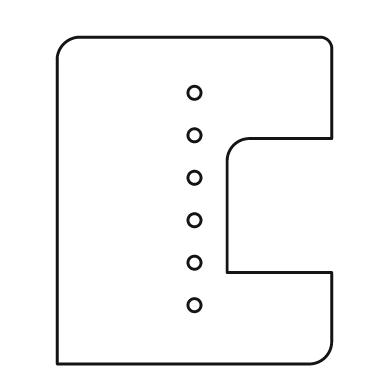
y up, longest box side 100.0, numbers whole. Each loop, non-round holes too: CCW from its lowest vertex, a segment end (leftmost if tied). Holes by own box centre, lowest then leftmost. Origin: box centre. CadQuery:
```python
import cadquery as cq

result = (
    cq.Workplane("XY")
    .moveTo(-42.0, -50.0)
    .lineTo(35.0, -50.0)
    .threePointArc((40.0, -48.0), (42.0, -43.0))
    .lineTo(42.0, -22.0)
    .lineTo(10.0, -22.0)
    .lineTo(10.0, 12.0)
    .threePointArc((12.0, 17.0), (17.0, 19.0))
    .lineTo(42.0, 19.0)
    .lineTo(42.0, 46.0)
    .threePointArc((41.0, 49.0), (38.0, 50.0))
    .lineTo(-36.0, 50.0)
    .threePointArc((-40.0, 48.0), (-42.0, 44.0))
    .close()
    .moveTo(0.0, -32.0)
    .circle(2.0)
    .moveTo(0.0, -19.0)
    .circle(2.0)
    .moveTo(0.0, -6.0)
    .circle(2.0)
    .moveTo(0.0, 7.0)
    .circle(2.0)
    .moveTo(0.0, 20.0)
    .circle(2.0)
    .moveTo(0.0, 33.0)
    .circle(2.0)
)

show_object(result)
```